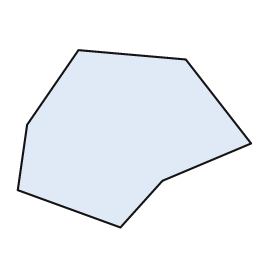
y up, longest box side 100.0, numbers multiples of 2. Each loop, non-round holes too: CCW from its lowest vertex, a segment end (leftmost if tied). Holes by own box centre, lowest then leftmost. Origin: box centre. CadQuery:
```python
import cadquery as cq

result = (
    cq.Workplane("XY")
    .moveTo(-6.0, -38.0)
    .lineTo(12.0, -18.0)
    .lineTo(50.0, -2.0)
    .lineTo(22.0, 34.0)
    .lineTo(-24.0, 38.0)
    .lineTo(-46.0, 6.0)
    .lineTo(-50.0, -22.0)
    .close()
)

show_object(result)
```